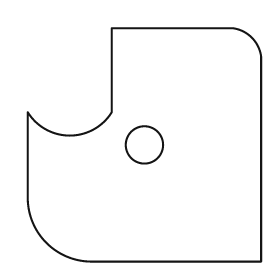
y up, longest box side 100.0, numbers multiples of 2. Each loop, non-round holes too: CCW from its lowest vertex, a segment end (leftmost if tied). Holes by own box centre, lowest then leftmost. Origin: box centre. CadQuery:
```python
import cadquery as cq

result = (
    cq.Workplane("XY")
    .moveTo(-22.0, -50.0)
    .lineTo(50.0, -50.0)
    .lineTo(50.0, 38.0)
    .threePointArc((46.0, 46.0), (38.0, 50.0))
    .lineTo(-14.0, 50.0)
    .lineTo(-14.0, 14.0)
    .threePointArc((-32.0, 4.0), (-50.0, 14.0))
    .lineTo(-50.0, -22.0)
    .threePointArc((-42.0, -42.0), (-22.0, -50.0))
    .close()
    .moveTo(0.0, 0.0)
    .circle(8.0)
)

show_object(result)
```